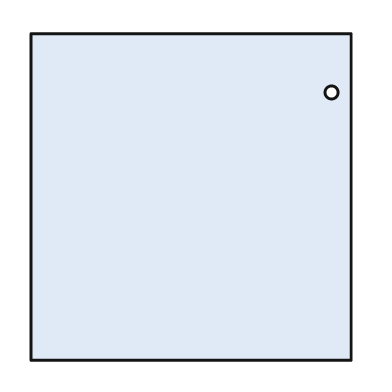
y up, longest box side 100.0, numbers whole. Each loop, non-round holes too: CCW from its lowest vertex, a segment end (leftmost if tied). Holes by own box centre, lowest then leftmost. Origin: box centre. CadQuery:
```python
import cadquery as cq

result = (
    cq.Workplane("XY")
    .moveTo(-49.0, -50.0)
    .lineTo(49.0, -50.0)
    .lineTo(49.0, 50.0)
    .lineTo(-49.0, 50.0)
    .close()
    .moveTo(43.0, 32.0)
    .circle(2.0)
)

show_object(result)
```